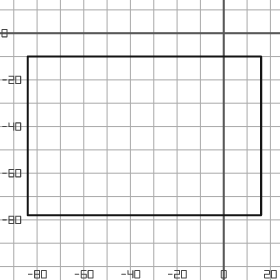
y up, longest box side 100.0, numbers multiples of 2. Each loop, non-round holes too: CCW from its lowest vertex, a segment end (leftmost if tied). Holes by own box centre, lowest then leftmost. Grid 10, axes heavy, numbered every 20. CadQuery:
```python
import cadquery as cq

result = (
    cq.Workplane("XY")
    .moveTo(-84.0, -78.0)
    .lineTo(16.0, -78.0)
    .lineTo(16.0, -10.0)
    .lineTo(-84.0, -10.0)
    .close()
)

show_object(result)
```